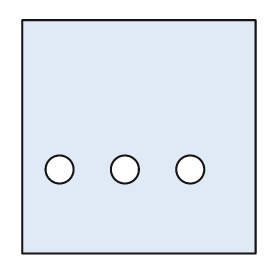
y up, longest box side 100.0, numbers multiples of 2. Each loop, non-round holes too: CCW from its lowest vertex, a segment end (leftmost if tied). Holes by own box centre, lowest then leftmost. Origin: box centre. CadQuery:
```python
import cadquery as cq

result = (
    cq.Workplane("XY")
    .moveTo(-50.0, -50.0)
    .lineTo(50.0, -50.0)
    .lineTo(50.0, 50.0)
    .lineTo(-50.0, 50.0)
    .close()
    .moveTo(-34.0, -14.0)
    .circle(6.0)
    .moveTo(-6.0, -14.0)
    .circle(6.0)
    .moveTo(22.0, -14.0)
    .circle(6.0)
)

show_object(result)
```